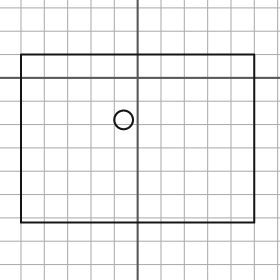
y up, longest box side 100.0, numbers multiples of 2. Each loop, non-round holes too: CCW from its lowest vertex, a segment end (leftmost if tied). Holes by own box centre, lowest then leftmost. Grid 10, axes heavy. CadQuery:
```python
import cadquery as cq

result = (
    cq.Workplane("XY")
    .moveTo(-50.0, -62.0)
    .lineTo(50.0, -62.0)
    .lineTo(50.0, 10.0)
    .lineTo(-50.0, 10.0)
    .close()
    .moveTo(-6.0, -18.0)
    .circle(4.0)
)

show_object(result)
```